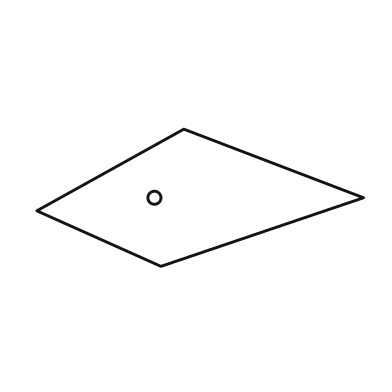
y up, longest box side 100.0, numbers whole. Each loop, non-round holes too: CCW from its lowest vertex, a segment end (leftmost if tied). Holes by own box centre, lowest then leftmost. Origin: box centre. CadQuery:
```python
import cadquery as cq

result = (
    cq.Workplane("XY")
    .moveTo(-12.0, -21.0)
    .lineTo(50.0, 0.0)
    .lineTo(-5.0, 21.0)
    .lineTo(-50.0, -4.0)
    .close()
    .moveTo(-14.0, 0.0)
    .circle(2.0)
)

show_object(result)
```